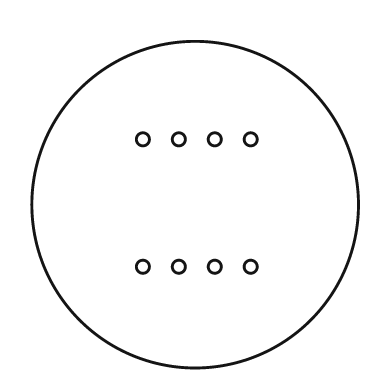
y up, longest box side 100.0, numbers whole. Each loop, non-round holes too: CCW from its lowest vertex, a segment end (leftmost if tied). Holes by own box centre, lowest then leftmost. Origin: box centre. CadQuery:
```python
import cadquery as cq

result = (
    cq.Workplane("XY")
    .moveTo(0.0, 0.0)
    .circle(50.0)
    .moveTo(-16.0, -19.0)
    .circle(2.0)
    .moveTo(-5.0, -19.0)
    .circle(2.0)
    .moveTo(6.0, -19.0)
    .circle(2.0)
    .moveTo(17.0, -19.0)
    .circle(2.0)
    .moveTo(-16.0, 20.0)
    .circle(2.0)
    .moveTo(-5.0, 20.0)
    .circle(2.0)
    .moveTo(6.0, 20.0)
    .circle(2.0)
    .moveTo(17.0, 20.0)
    .circle(2.0)
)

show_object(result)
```